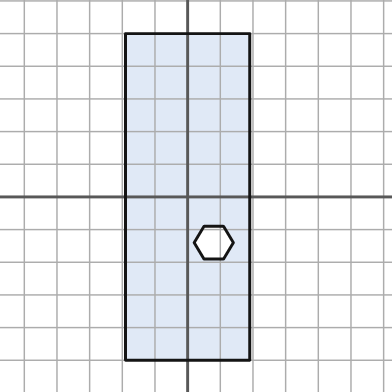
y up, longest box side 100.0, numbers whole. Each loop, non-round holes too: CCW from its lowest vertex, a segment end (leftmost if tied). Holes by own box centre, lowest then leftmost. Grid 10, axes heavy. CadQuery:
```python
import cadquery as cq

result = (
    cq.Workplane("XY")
    .moveTo(-19.0, -50.0)
    .lineTo(19.0, -50.0)
    .lineTo(19.0, 50.0)
    .lineTo(-19.0, 50.0)
    .close()
    .moveTo(5.0, -19.0)
    .lineTo(11.0, -19.0)
    .lineTo(14.0, -14.0)
    .lineTo(11.0, -9.0)
    .lineTo(5.0, -9.0)
    .lineTo(2.0, -14.0)
    .close()
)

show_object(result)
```